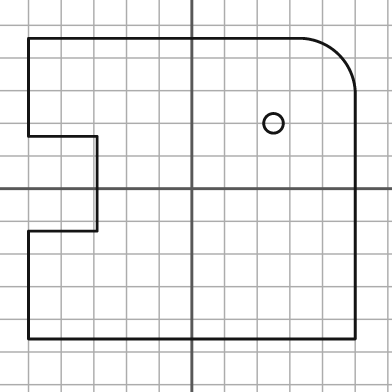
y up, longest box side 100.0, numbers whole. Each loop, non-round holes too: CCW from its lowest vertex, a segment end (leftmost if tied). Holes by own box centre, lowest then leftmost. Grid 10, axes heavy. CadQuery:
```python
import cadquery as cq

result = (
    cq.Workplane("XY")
    .moveTo(-50.0, -46.0)
    .lineTo(50.0, -46.0)
    .lineTo(50.0, 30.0)
    .threePointArc((45.0, 41.0), (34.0, 46.0))
    .lineTo(-50.0, 46.0)
    .lineTo(-50.0, 16.0)
    .lineTo(-29.0, 16.0)
    .lineTo(-29.0, -13.0)
    .lineTo(-50.0, -13.0)
    .close()
    .moveTo(25.0, 20.0)
    .circle(3.0)
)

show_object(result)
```